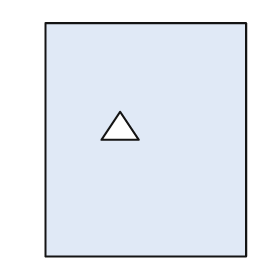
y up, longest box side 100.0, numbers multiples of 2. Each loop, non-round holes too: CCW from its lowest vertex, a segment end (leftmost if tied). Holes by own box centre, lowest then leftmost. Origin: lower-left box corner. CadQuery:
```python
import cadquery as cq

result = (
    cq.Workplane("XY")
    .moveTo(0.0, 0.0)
    .lineTo(86.0, 0.0)
    .lineTo(86.0, 100.0)
    .lineTo(0.0, 100.0)
    .close()
    .moveTo(24.0, 50.0)
    .lineTo(40.0, 50.0)
    .lineTo(32.0, 62.0)
    .close()
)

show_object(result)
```